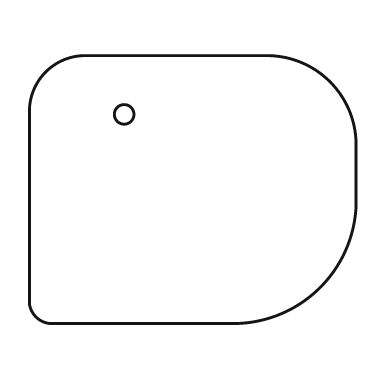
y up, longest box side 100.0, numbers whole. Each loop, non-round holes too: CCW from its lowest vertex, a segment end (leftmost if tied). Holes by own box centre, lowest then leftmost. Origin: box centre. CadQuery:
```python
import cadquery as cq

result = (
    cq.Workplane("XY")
    .moveTo(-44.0, -41.0)
    .lineTo(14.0, -41.0)
    .threePointArc((39.0, -30.0), (50.0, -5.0))
    .lineTo(50.0, 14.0)
    .threePointArc((42.0, 33.0), (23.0, 41.0))
    .lineTo(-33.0, 41.0)
    .threePointArc((-45.0, 36.0), (-50.0, 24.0))
    .lineTo(-50.0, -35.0)
    .threePointArc((-48.0, -39.0), (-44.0, -41.0))
    .close()
    .moveTo(-21.0, 23.0)
    .circle(3.0)
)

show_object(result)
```